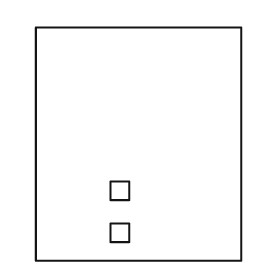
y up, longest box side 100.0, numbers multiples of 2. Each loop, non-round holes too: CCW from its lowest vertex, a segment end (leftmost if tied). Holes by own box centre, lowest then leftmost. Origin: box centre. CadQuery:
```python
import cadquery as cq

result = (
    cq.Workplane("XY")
    .moveTo(-44.0, -50.0)
    .lineTo(44.0, -50.0)
    .lineTo(44.0, 50.0)
    .lineTo(-44.0, 50.0)
    .close()
    .moveTo(-12.0, -42.0)
    .lineTo(-4.0, -42.0)
    .lineTo(-4.0, -34.0)
    .lineTo(-12.0, -34.0)
    .close()
    .moveTo(-12.0, -24.0)
    .lineTo(-4.0, -24.0)
    .lineTo(-4.0, -16.0)
    .lineTo(-12.0, -16.0)
    .close()
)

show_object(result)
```